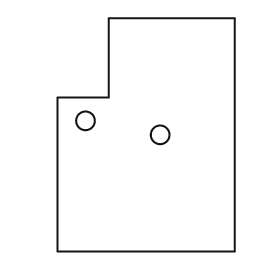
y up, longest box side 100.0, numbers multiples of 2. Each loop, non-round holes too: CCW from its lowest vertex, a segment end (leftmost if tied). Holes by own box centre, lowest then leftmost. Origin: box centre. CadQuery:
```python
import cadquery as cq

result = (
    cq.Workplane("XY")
    .moveTo(-38.0, -50.0)
    .lineTo(38.0, -50.0)
    .lineTo(38.0, 50.0)
    .lineTo(-16.0, 50.0)
    .lineTo(-16.0, 16.0)
    .lineTo(-38.0, 16.0)
    .close()
    .moveTo(6.0, 0.0)
    .circle(4.0)
    .moveTo(-26.0, 6.0)
    .circle(4.0)
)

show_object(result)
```